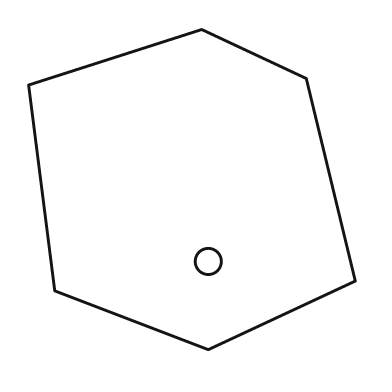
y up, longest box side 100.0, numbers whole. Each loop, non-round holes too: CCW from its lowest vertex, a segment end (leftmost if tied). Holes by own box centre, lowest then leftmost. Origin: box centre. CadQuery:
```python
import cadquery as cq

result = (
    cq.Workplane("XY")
    .moveTo(5.0, -49.0)
    .lineTo(50.0, -28.0)
    .lineTo(35.0, 34.0)
    .lineTo(3.0, 49.0)
    .lineTo(-50.0, 32.0)
    .lineTo(-42.0, -31.0)
    .close()
    .moveTo(5.0, -22.0)
    .circle(4.0)
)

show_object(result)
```